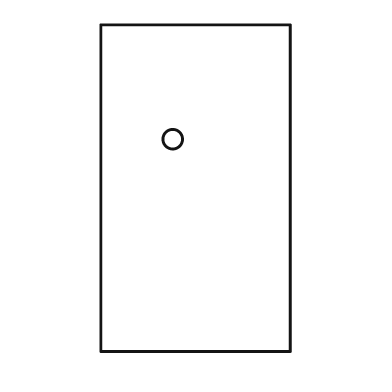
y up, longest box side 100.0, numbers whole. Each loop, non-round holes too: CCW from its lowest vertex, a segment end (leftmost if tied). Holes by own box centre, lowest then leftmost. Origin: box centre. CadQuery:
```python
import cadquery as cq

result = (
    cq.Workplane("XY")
    .moveTo(-29.0, -50.0)
    .lineTo(29.0, -50.0)
    .lineTo(29.0, 50.0)
    .lineTo(-29.0, 50.0)
    .close()
    .moveTo(-7.0, 15.0)
    .circle(3.0)
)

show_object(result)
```